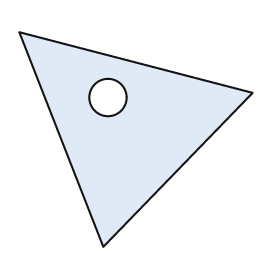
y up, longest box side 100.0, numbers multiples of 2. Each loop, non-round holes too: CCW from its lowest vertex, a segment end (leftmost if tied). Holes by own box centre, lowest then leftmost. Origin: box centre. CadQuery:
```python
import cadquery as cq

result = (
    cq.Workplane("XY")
    .moveTo(-14.0, -46.0)
    .lineTo(50.0, 20.0)
    .lineTo(-50.0, 46.0)
    .close()
    .moveTo(-12.0, 18.0)
    .circle(8.0)
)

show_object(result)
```